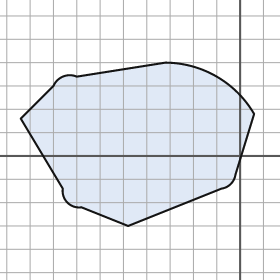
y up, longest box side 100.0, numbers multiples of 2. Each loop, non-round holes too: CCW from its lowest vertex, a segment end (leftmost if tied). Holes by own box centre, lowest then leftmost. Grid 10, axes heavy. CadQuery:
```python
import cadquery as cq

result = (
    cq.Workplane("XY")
    .moveTo(-48.0, -30.0)
    .lineTo(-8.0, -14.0)
    .threePointArc((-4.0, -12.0), (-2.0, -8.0))
    .lineTo(6.0, 18.0)
    .threePointArc((-10.0, 34.0), (-32.0, 40.0))
    .lineTo(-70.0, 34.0)
    .threePointArc((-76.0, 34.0), (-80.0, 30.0))
    .lineTo(-94.0, 16.0)
    .lineTo(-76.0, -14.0)
    .threePointArc((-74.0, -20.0), (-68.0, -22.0))
    .close()
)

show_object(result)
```